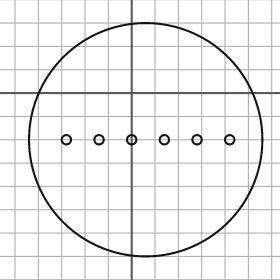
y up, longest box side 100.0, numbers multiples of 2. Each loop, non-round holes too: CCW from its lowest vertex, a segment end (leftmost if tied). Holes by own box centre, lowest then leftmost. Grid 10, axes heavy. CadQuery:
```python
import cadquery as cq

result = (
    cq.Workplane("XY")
    .moveTo(6.0, -20.0)
    .circle(50.0)
    .moveTo(-28.0, -20.0)
    .circle(2.0)
    .moveTo(-14.0, -20.0)
    .circle(2.0)
    .moveTo(0.0, -20.0)
    .circle(2.0)
    .moveTo(14.0, -20.0)
    .circle(2.0)
    .moveTo(28.0, -20.0)
    .circle(2.0)
    .moveTo(42.0, -20.0)
    .circle(2.0)
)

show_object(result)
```